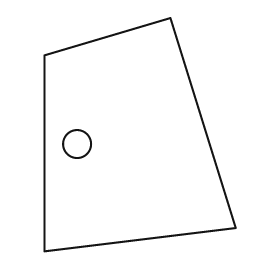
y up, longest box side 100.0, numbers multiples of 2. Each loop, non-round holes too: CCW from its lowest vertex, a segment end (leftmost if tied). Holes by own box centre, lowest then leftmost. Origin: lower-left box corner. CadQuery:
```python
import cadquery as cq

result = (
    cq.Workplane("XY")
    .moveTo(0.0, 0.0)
    .lineTo(82.0, 10.0)
    .lineTo(54.0, 100.0)
    .lineTo(0.0, 84.0)
    .close()
    .moveTo(14.0, 46.0)
    .circle(6.0)
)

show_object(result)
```